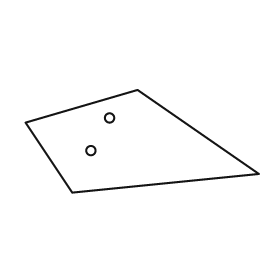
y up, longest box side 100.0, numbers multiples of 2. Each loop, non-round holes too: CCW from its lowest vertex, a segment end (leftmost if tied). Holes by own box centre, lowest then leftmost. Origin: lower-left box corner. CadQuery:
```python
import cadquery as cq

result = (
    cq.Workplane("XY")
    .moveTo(20.0, 0.0)
    .lineTo(100.0, 8.0)
    .lineTo(48.0, 44.0)
    .lineTo(0.0, 30.0)
    .close()
    .moveTo(28.0, 18.0)
    .circle(2.0)
    .moveTo(36.0, 32.0)
    .circle(2.0)
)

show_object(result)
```